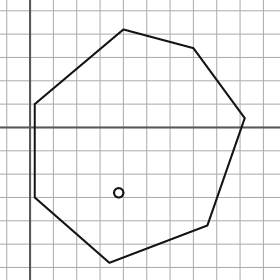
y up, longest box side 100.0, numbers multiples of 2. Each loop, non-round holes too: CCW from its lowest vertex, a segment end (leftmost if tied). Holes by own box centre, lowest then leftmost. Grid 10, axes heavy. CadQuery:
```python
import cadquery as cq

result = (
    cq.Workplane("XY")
    .moveTo(34.0, -58.0)
    .lineTo(76.0, -42.0)
    .lineTo(92.0, 4.0)
    .lineTo(70.0, 34.0)
    .lineTo(40.0, 42.0)
    .lineTo(2.0, 10.0)
    .lineTo(2.0, -30.0)
    .close()
    .moveTo(38.0, -28.0)
    .circle(2.0)
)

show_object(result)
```